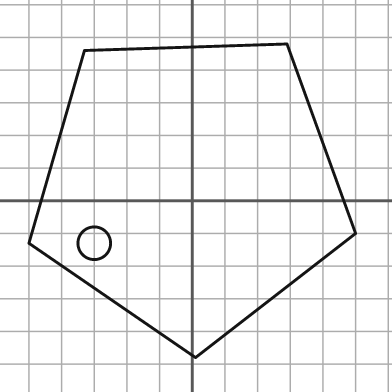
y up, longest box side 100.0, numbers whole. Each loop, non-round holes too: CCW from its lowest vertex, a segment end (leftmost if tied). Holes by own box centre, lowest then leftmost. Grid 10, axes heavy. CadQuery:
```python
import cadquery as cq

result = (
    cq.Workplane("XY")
    .moveTo(1.0, -48.0)
    .lineTo(50.0, -10.0)
    .lineTo(29.0, 48.0)
    .lineTo(-33.0, 46.0)
    .lineTo(-50.0, -13.0)
    .close()
    .moveTo(-30.0, -13.0)
    .circle(5.0)
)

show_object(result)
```